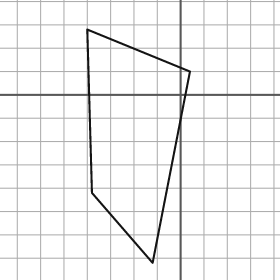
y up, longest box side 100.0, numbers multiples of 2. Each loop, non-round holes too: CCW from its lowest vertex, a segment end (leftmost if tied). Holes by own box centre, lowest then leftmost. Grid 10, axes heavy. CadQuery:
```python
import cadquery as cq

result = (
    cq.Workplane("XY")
    .moveTo(-12.0, -72.0)
    .lineTo(4.0, 10.0)
    .lineTo(-40.0, 28.0)
    .lineTo(-38.0, -42.0)
    .close()
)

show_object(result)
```